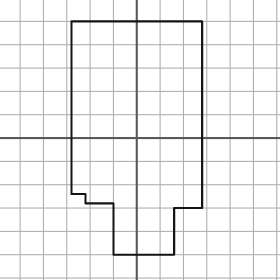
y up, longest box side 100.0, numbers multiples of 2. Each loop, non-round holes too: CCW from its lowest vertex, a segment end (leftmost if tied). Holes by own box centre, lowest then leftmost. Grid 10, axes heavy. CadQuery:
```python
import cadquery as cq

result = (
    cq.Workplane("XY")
    .moveTo(-10.0, -50.0)
    .lineTo(16.0, -50.0)
    .lineTo(16.0, -30.0)
    .lineTo(28.0, -30.0)
    .lineTo(28.0, 50.0)
    .lineTo(-28.0, 50.0)
    .lineTo(-28.0, -24.0)
    .lineTo(-22.0, -24.0)
    .lineTo(-22.0, -28.0)
    .lineTo(-10.0, -28.0)
    .close()
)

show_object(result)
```